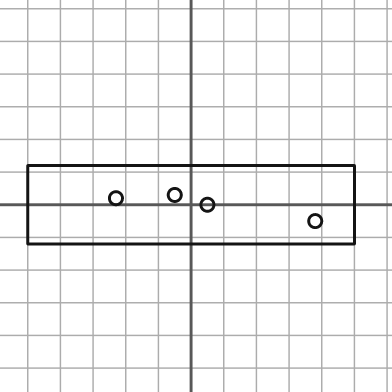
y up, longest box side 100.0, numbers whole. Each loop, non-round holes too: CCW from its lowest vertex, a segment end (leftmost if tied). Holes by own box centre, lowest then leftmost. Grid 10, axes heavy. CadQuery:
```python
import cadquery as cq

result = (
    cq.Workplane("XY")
    .moveTo(-50.0, -12.0)
    .lineTo(50.0, -12.0)
    .lineTo(50.0, 12.0)
    .lineTo(-50.0, 12.0)
    .close()
    .moveTo(38.0, -5.0)
    .circle(2.0)
    .moveTo(5.0, 0.0)
    .circle(2.0)
    .moveTo(-23.0, 2.0)
    .circle(2.0)
    .moveTo(-5.0, 3.0)
    .circle(2.0)
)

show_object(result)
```